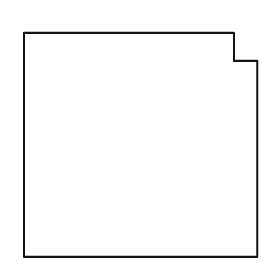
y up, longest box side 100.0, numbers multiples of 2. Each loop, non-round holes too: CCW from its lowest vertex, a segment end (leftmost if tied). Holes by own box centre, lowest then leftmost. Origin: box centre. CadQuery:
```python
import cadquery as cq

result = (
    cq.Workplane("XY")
    .moveTo(-50.0, -48.0)
    .lineTo(50.0, -48.0)
    .lineTo(50.0, 36.0)
    .lineTo(40.0, 36.0)
    .lineTo(40.0, 48.0)
    .lineTo(-50.0, 48.0)
    .close()
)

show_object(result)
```